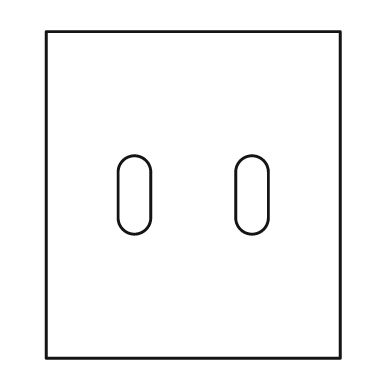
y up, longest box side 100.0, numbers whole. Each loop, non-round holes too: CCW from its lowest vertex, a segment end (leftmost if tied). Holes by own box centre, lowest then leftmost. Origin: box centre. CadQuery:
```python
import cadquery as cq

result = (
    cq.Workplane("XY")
    .moveTo(-45.0, -50.0)
    .lineTo(45.0, -50.0)
    .lineTo(45.0, 50.0)
    .lineTo(-45.0, 50.0)
    .close()
    .moveTo(-23.0, -7.0)
    .threePointArc((-18.0, -12.0), (-13.0, -7.0))
    .lineTo(-13.0, 7.0)
    .threePointArc((-18.0, 12.0), (-23.0, 7.0))
    .close()
    .moveTo(13.0, -7.0)
    .threePointArc((18.0, -12.0), (23.0, -7.0))
    .lineTo(23.0, 7.0)
    .threePointArc((18.0, 12.0), (13.0, 7.0))
    .close()
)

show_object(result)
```